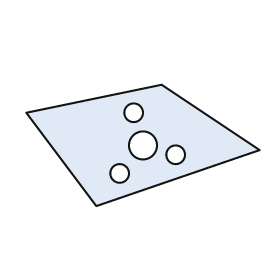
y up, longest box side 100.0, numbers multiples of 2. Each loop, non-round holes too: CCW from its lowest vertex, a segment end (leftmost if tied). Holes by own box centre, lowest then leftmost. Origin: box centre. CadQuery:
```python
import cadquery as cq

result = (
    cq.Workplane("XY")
    .moveTo(-20.0, -26.0)
    .lineTo(50.0, -2.0)
    .lineTo(8.0, 26.0)
    .lineTo(-50.0, 14.0)
    .close()
    .moveTo(-10.0, -12.0)
    .circle(4.0)
    .moveTo(14.0, -4.0)
    .circle(4.0)
    .moveTo(0.0, 0.0)
    .circle(6.0)
    .moveTo(-4.0, 14.0)
    .circle(4.0)
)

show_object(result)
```